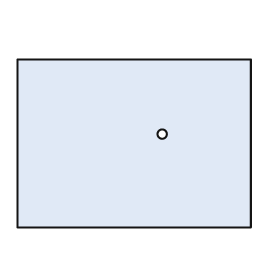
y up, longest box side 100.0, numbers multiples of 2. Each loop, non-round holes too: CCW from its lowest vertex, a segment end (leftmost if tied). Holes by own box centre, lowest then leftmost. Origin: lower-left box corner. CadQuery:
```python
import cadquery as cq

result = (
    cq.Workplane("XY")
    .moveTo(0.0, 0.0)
    .lineTo(100.0, 0.0)
    .lineTo(100.0, 72.0)
    .lineTo(0.0, 72.0)
    .close()
    .moveTo(62.0, 40.0)
    .circle(2.0)
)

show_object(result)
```